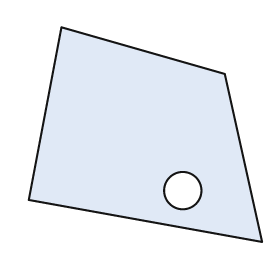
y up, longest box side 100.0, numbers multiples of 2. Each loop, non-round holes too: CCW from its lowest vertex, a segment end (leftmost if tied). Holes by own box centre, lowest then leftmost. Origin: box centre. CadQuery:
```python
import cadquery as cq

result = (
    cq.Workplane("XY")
    .moveTo(50.0, -46.0)
    .lineTo(34.0, 26.0)
    .lineTo(-36.0, 46.0)
    .lineTo(-50.0, -28.0)
    .close()
    .moveTo(16.0, -24.0)
    .circle(8.0)
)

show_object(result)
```